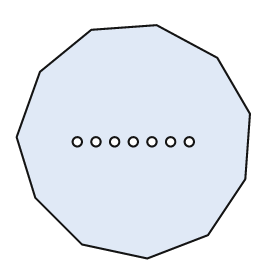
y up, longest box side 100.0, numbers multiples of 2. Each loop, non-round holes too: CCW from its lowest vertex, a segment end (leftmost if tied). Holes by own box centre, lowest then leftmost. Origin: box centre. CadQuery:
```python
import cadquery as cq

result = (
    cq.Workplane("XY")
    .moveTo(6.0, -50.0)
    .lineTo(32.0, -40.0)
    .lineTo(48.0, -16.0)
    .lineTo(50.0, 12.0)
    .lineTo(36.0, 36.0)
    .lineTo(10.0, 50.0)
    .lineTo(-18.0, 48.0)
    .lineTo(-40.0, 30.0)
    .lineTo(-50.0, 2.0)
    .lineTo(-42.0, -24.0)
    .lineTo(-22.0, -44.0)
    .close()
    .moveTo(-24.0, 0.0)
    .circle(2.0)
    .moveTo(-16.0, 0.0)
    .circle(2.0)
    .moveTo(-8.0, 0.0)
    .circle(2.0)
    .moveTo(0.0, 0.0)
    .circle(2.0)
    .moveTo(8.0, 0.0)
    .circle(2.0)
    .moveTo(16.0, 0.0)
    .circle(2.0)
    .moveTo(24.0, 0.0)
    .circle(2.0)
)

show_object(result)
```